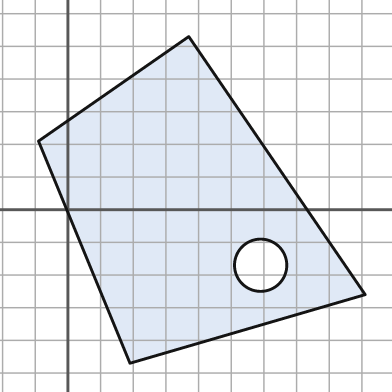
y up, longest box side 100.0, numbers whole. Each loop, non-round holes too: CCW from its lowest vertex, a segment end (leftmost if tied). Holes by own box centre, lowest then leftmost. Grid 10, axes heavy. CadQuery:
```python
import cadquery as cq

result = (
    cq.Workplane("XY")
    .moveTo(19.0, -47.0)
    .lineTo(91.0, -26.0)
    .lineTo(37.0, 53.0)
    .lineTo(-9.0, 21.0)
    .close()
    .moveTo(59.0, -17.0)
    .circle(8.0)
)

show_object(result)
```